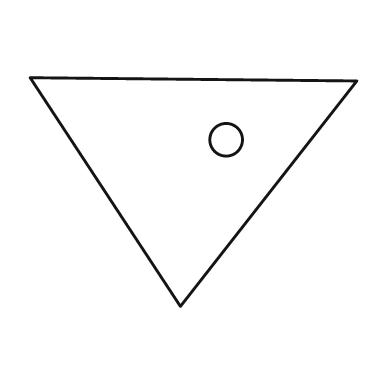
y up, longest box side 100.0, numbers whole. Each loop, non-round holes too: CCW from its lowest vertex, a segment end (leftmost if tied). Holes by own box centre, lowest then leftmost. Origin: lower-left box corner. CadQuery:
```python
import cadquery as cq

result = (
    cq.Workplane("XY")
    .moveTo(46.0, 0.0)
    .lineTo(100.0, 69.0)
    .lineTo(0.0, 70.0)
    .close()
    .moveTo(60.0, 51.0)
    .circle(5.0)
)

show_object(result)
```